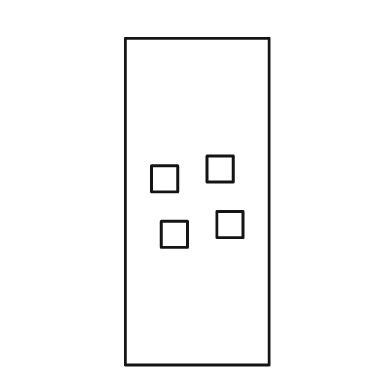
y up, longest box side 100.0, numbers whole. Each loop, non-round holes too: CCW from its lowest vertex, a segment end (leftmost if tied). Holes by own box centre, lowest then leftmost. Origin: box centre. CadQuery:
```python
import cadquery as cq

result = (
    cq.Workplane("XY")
    .moveTo(-22.0, -50.0)
    .lineTo(22.0, -50.0)
    .lineTo(22.0, 50.0)
    .lineTo(-22.0, 50.0)
    .close()
    .moveTo(-11.0, -14.0)
    .lineTo(-3.0, -14.0)
    .lineTo(-3.0, -6.0)
    .lineTo(-11.0, -6.0)
    .close()
    .moveTo(6.0, -11.0)
    .lineTo(14.0, -11.0)
    .lineTo(14.0, -3.0)
    .lineTo(6.0, -3.0)
    .close()
    .moveTo(-14.0, 3.0)
    .lineTo(-6.0, 3.0)
    .lineTo(-6.0, 11.0)
    .lineTo(-14.0, 11.0)
    .close()
    .moveTo(3.0, 6.0)
    .lineTo(11.0, 6.0)
    .lineTo(11.0, 14.0)
    .lineTo(3.0, 14.0)
    .close()
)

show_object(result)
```